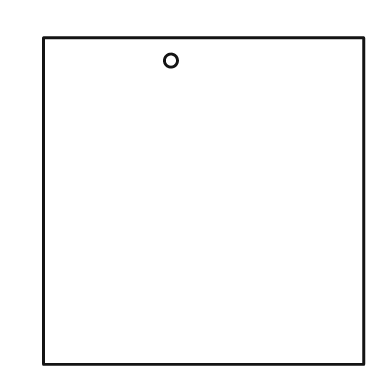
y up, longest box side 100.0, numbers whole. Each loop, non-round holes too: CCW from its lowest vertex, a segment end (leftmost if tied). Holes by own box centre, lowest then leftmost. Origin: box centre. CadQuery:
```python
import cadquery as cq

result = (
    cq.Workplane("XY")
    .moveTo(-49.0, -50.0)
    .lineTo(49.0, -50.0)
    .lineTo(49.0, 50.0)
    .lineTo(-49.0, 50.0)
    .close()
    .moveTo(-10.0, 43.0)
    .circle(2.0)
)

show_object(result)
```